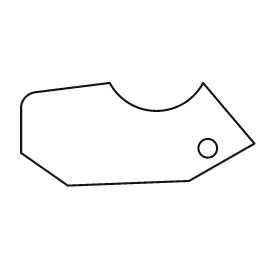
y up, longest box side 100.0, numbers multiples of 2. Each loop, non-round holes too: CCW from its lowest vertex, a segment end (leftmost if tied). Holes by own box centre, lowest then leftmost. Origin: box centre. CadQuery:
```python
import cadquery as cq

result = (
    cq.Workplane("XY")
    .moveTo(-30.0, -22.0)
    .lineTo(22.0, -20.0)
    .lineTo(50.0, -4.0)
    .lineTo(28.0, 22.0)
    .threePointArc((8.0, 10.0), (-12.0, 22.0))
    .lineTo(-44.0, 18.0)
    .threePointArc((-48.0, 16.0), (-50.0, 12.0))
    .lineTo(-50.0, -8.0)
    .close()
    .moveTo(30.0, -6.0)
    .circle(4.0)
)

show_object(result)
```